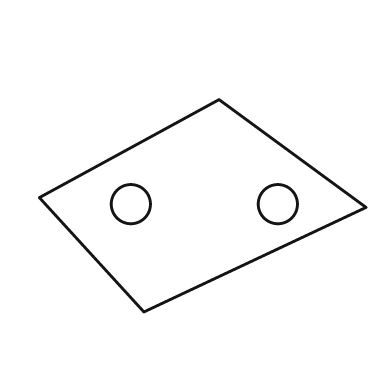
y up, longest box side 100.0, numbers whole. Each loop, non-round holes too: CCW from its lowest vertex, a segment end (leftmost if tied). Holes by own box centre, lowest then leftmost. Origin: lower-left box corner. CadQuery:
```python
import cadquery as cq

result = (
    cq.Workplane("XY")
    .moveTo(32.0, 0.0)
    .lineTo(100.0, 32.0)
    .lineTo(55.0, 65.0)
    .lineTo(0.0, 35.0)
    .close()
    .moveTo(28.0, 33.0)
    .circle(6.0)
    .moveTo(73.0, 33.0)
    .circle(6.0)
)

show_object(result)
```